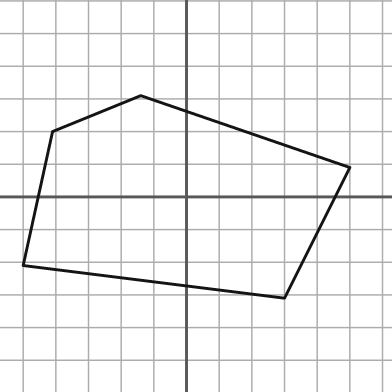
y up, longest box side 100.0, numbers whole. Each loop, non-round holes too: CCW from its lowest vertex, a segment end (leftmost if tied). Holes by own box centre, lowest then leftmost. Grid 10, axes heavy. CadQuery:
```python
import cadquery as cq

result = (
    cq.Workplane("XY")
    .moveTo(30.0, -31.0)
    .lineTo(50.0, 9.0)
    .lineTo(-14.0, 31.0)
    .lineTo(-41.0, 20.0)
    .lineTo(-50.0, -21.0)
    .close()
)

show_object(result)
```